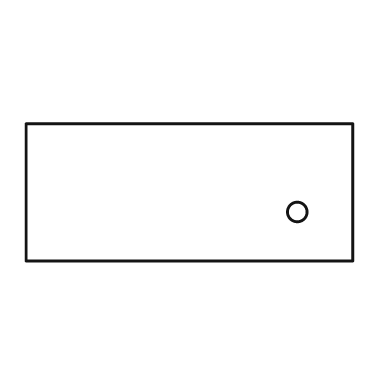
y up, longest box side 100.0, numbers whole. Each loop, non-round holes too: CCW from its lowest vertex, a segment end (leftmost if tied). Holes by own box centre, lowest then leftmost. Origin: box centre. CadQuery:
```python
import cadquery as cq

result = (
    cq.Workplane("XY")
    .moveTo(-50.0, -21.0)
    .lineTo(50.0, -21.0)
    .lineTo(50.0, 21.0)
    .lineTo(-50.0, 21.0)
    .close()
    .moveTo(33.0, -6.0)
    .circle(3.0)
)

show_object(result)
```